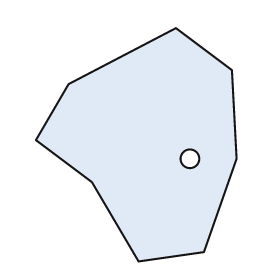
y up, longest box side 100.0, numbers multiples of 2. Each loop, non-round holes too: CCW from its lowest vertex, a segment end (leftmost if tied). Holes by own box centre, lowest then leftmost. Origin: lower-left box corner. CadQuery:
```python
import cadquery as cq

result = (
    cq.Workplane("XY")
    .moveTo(44.0, 0.0)
    .lineTo(72.0, 4.0)
    .lineTo(86.0, 44.0)
    .lineTo(84.0, 82.0)
    .lineTo(60.0, 100.0)
    .lineTo(14.0, 76.0)
    .lineTo(0.0, 52.0)
    .lineTo(24.0, 34.0)
    .close()
    .moveTo(66.0, 44.0)
    .circle(4.0)
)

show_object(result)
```